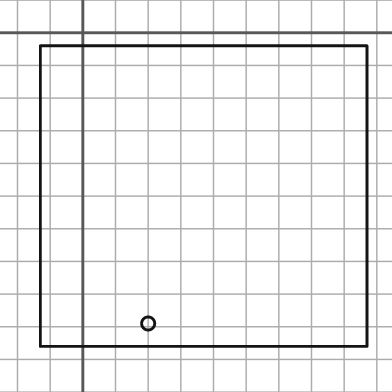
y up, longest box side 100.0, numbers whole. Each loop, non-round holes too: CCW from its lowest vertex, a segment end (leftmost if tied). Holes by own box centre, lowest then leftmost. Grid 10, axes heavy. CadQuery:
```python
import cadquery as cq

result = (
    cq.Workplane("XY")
    .moveTo(-13.0, -96.0)
    .lineTo(87.0, -96.0)
    .lineTo(87.0, -4.0)
    .lineTo(-13.0, -4.0)
    .close()
    .moveTo(20.0, -89.0)
    .circle(2.0)
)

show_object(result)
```